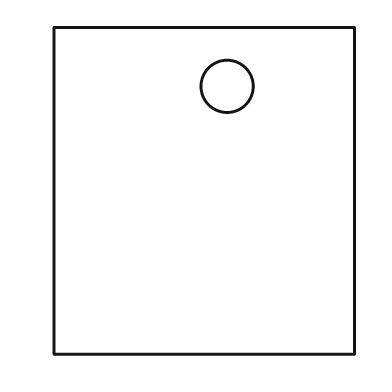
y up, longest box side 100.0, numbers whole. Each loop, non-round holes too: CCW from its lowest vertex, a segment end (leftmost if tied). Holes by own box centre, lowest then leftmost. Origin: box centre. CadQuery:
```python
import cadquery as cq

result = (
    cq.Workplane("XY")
    .moveTo(-46.0, -50.0)
    .lineTo(46.0, -50.0)
    .lineTo(46.0, 50.0)
    .lineTo(-46.0, 50.0)
    .close()
    .moveTo(7.0, 32.0)
    .circle(8.0)
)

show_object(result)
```